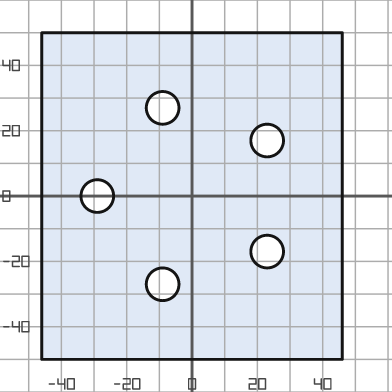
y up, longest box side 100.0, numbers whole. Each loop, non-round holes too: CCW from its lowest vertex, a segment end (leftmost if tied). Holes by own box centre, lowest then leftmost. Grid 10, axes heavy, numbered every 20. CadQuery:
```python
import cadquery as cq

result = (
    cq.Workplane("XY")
    .moveTo(-46.0, -50.0)
    .lineTo(46.0, -50.0)
    .lineTo(46.0, 50.0)
    .lineTo(-46.0, 50.0)
    .close()
    .moveTo(-9.0, -27.0)
    .circle(5.0)
    .moveTo(23.0, -17.0)
    .circle(5.0)
    .moveTo(-29.0, 0.0)
    .circle(5.0)
    .moveTo(23.0, 17.0)
    .circle(5.0)
    .moveTo(-9.0, 27.0)
    .circle(5.0)
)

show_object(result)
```